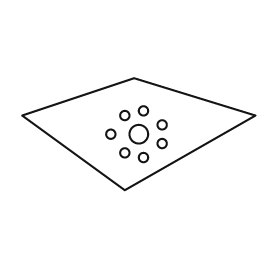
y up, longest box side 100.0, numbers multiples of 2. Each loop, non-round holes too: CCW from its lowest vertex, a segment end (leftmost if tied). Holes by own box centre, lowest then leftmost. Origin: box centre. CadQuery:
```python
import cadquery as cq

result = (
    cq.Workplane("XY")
    .moveTo(-6.0, -24.0)
    .lineTo(50.0, 8.0)
    .lineTo(-2.0, 24.0)
    .lineTo(-50.0, 8.0)
    .close()
    .moveTo(2.0, -10.0)
    .circle(2.0)
    .moveTo(-6.0, -8.0)
    .circle(2.0)
    .moveTo(10.0, -4.0)
    .circle(2.0)
    .moveTo(-12.0, 0.0)
    .circle(2.0)
    .moveTo(0.0, 0.0)
    .circle(4.0)
    .moveTo(10.0, 4.0)
    .circle(2.0)
    .moveTo(-6.0, 8.0)
    .circle(2.0)
    .moveTo(2.0, 10.0)
    .circle(2.0)
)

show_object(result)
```